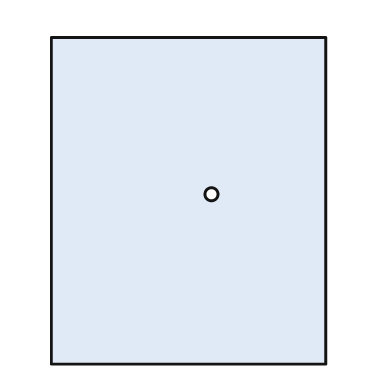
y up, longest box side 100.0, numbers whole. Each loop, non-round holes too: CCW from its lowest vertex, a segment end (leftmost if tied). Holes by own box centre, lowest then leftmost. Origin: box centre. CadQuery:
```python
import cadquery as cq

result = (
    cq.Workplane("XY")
    .moveTo(-42.0, -50.0)
    .lineTo(42.0, -50.0)
    .lineTo(42.0, 50.0)
    .lineTo(-42.0, 50.0)
    .close()
    .moveTo(7.0, 2.0)
    .circle(2.0)
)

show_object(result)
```